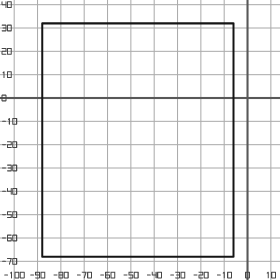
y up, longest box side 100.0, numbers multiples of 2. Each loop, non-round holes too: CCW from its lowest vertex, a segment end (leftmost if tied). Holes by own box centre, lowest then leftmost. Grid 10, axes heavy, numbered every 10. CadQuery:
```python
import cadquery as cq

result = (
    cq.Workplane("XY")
    .moveTo(-88.0, -68.0)
    .lineTo(-6.0, -68.0)
    .lineTo(-6.0, 32.0)
    .lineTo(-88.0, 32.0)
    .close()
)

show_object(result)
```